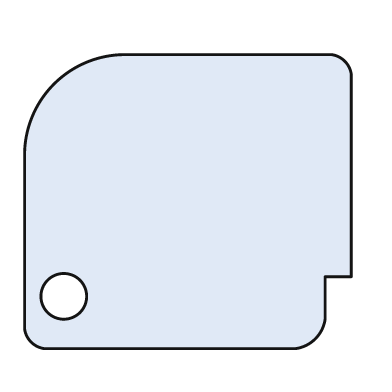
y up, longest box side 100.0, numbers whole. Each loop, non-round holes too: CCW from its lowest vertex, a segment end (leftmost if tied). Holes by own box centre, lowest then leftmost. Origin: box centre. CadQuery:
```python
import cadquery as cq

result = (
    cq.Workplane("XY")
    .moveTo(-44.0, -45.0)
    .lineTo(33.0, -45.0)
    .threePointArc((39.0, -42.0), (42.0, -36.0))
    .lineTo(42.0, -23.0)
    .lineTo(50.0, -23.0)
    .lineTo(50.0, 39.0)
    .threePointArc((48.0, 43.0), (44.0, 45.0))
    .lineTo(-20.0, 45.0)
    .threePointArc((-41.0, 36.0), (-50.0, 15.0))
    .lineTo(-50.0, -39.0)
    .threePointArc((-48.0, -43.0), (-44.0, -45.0))
    .close()
    .moveTo(-38.0, -29.0)
    .circle(7.0)
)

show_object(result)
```